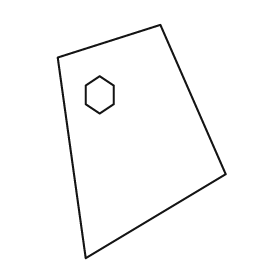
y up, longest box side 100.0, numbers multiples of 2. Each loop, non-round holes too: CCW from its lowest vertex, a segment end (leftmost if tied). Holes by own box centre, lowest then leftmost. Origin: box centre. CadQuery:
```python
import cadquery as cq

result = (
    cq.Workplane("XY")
    .moveTo(-24.0, -50.0)
    .lineTo(36.0, -14.0)
    .lineTo(8.0, 50.0)
    .lineTo(-36.0, 36.0)
    .close()
    .moveTo(-18.0, 12.0)
    .lineTo(-12.0, 16.0)
    .lineTo(-12.0, 24.0)
    .lineTo(-18.0, 28.0)
    .lineTo(-24.0, 24.0)
    .lineTo(-24.0, 16.0)
    .close()
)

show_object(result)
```